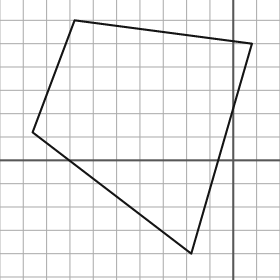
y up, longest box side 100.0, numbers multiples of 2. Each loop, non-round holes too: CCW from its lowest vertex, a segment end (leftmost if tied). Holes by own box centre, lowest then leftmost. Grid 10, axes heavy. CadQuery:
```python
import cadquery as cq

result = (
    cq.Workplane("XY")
    .moveTo(-18.0, -40.0)
    .lineTo(8.0, 50.0)
    .lineTo(-68.0, 60.0)
    .lineTo(-86.0, 12.0)
    .close()
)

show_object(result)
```